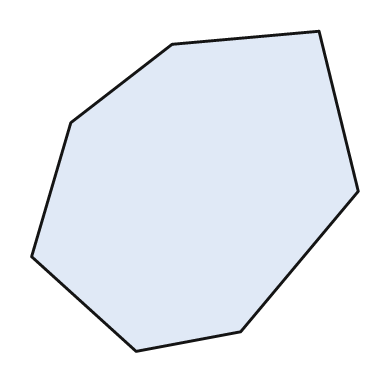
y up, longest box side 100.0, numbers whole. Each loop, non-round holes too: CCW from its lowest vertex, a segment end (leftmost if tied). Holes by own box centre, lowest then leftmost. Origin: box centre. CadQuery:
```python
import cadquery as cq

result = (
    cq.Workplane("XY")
    .moveTo(-18.0, -49.0)
    .lineTo(14.0, -43.0)
    .lineTo(50.0, 0.0)
    .lineTo(38.0, 49.0)
    .lineTo(-7.0, 45.0)
    .lineTo(-38.0, 21.0)
    .lineTo(-50.0, -20.0)
    .close()
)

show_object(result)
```